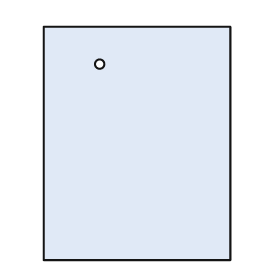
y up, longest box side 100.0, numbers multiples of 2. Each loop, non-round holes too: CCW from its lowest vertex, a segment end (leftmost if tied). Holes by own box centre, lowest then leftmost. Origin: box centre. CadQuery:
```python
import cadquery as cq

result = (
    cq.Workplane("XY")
    .moveTo(-40.0, -50.0)
    .lineTo(40.0, -50.0)
    .lineTo(40.0, 50.0)
    .lineTo(-40.0, 50.0)
    .close()
    .moveTo(-16.0, 34.0)
    .circle(2.0)
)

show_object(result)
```